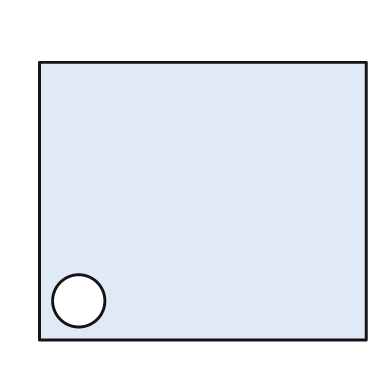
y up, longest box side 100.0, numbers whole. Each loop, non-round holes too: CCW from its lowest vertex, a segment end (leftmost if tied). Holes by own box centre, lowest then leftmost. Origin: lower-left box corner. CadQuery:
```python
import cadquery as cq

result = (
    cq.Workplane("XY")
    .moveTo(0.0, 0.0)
    .lineTo(100.0, 0.0)
    .lineTo(100.0, 85.0)
    .lineTo(0.0, 85.0)
    .close()
    .moveTo(12.0, 12.0)
    .circle(8.0)
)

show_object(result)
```